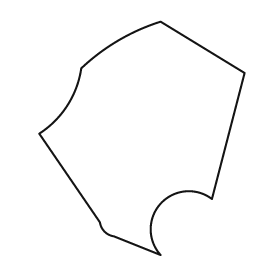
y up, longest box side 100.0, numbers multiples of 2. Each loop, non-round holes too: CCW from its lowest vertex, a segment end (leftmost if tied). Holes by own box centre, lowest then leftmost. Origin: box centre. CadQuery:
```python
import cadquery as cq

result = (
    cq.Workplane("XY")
    .moveTo(8.0, -50.0)
    .threePointArc((8.0, -28.0), (30.0, -26.0))
    .lineTo(44.0, 28.0)
    .lineTo(8.0, 50.0)
    .threePointArc((-10.0, 42.0), (-26.0, 30.0))
    .threePointArc((-32.0, 14.0), (-44.0, 2.0))
    .lineTo(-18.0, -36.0)
    .threePointArc((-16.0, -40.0), (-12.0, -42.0))
    .close()
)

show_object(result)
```